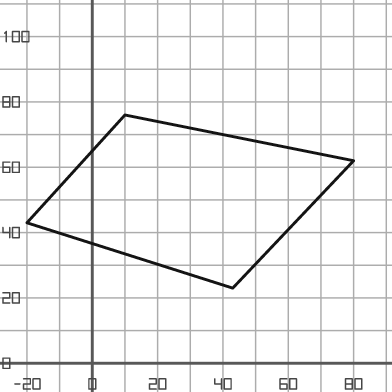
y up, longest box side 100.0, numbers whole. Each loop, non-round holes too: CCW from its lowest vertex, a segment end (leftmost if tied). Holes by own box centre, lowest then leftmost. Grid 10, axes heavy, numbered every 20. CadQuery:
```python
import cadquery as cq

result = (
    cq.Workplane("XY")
    .moveTo(43.0, 23.0)
    .lineTo(80.0, 62.0)
    .lineTo(10.0, 76.0)
    .lineTo(-20.0, 43.0)
    .close()
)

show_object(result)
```